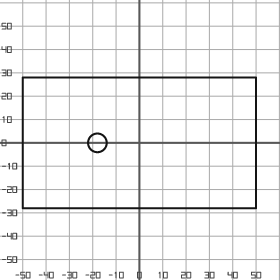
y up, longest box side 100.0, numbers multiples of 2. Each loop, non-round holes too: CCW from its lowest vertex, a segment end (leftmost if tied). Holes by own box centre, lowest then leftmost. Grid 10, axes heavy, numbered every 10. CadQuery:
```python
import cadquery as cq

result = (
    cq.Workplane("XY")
    .moveTo(-50.0, -28.0)
    .lineTo(50.0, -28.0)
    .lineTo(50.0, 28.0)
    .lineTo(-50.0, 28.0)
    .close()
    .moveTo(-18.0, 0.0)
    .circle(4.0)
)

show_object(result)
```